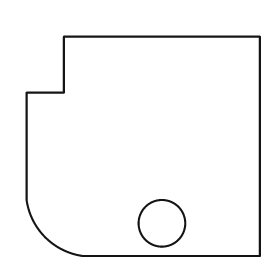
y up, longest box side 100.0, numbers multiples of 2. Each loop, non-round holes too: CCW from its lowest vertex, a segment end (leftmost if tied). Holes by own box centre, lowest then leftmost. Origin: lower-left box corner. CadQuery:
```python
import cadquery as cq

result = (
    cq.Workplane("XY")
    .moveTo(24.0, 0.0)
    .lineTo(100.0, 0.0)
    .lineTo(100.0, 94.0)
    .lineTo(16.0, 94.0)
    .lineTo(16.0, 70.0)
    .lineTo(0.0, 70.0)
    .lineTo(0.0, 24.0)
    .threePointArc((8.0, 8.0), (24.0, 0.0))
    .close()
    .moveTo(58.0, 14.0)
    .circle(10.0)
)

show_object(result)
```